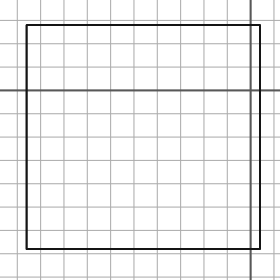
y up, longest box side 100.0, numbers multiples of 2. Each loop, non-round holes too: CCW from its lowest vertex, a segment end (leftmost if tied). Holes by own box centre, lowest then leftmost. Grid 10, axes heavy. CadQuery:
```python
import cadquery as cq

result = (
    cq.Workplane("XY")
    .moveTo(-96.0, -68.0)
    .lineTo(4.0, -68.0)
    .lineTo(4.0, 28.0)
    .lineTo(-96.0, 28.0)
    .close()
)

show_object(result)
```